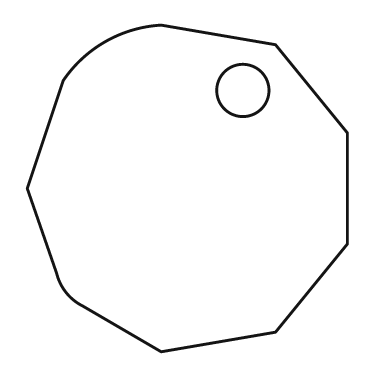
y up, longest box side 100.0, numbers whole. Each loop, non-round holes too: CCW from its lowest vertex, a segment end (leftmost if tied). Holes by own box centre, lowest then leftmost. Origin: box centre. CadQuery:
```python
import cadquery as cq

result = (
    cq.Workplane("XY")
    .moveTo(-8.0, -50.0)
    .lineTo(27.0, -44.0)
    .lineTo(49.0, -17.0)
    .lineTo(49.0, 17.0)
    .lineTo(27.0, 44.0)
    .lineTo(-8.0, 50.0)
    .threePointArc((-25.0, 45.0), (-38.0, 33.0))
    .lineTo(-49.0, 0.0)
    .lineTo(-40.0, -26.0)
    .threePointArc((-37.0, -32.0), (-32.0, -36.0))
    .close()
    .moveTo(17.0, 30.0)
    .circle(8.0)
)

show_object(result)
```